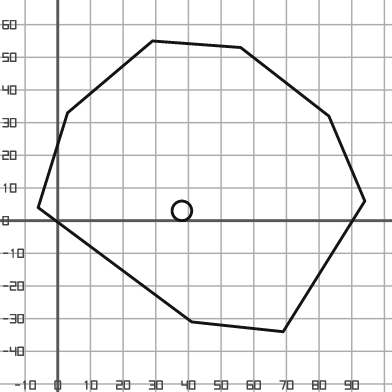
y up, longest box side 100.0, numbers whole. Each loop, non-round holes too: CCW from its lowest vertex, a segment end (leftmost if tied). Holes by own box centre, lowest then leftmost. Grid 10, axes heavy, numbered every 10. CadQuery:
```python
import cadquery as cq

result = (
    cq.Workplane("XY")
    .moveTo(69.0, -34.0)
    .lineTo(94.0, 6.0)
    .lineTo(83.0, 32.0)
    .lineTo(56.0, 53.0)
    .lineTo(29.0, 55.0)
    .lineTo(3.0, 33.0)
    .lineTo(-6.0, 4.0)
    .lineTo(41.0, -31.0)
    .close()
    .moveTo(38.0, 3.0)
    .circle(3.0)
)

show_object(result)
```